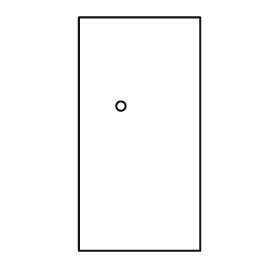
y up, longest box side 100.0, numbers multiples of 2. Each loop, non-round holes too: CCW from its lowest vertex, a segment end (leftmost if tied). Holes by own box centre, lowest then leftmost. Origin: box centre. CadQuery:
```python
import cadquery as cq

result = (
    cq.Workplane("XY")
    .moveTo(-26.0, -50.0)
    .lineTo(26.0, -50.0)
    .lineTo(26.0, 50.0)
    .lineTo(-26.0, 50.0)
    .close()
    .moveTo(-8.0, 12.0)
    .circle(2.0)
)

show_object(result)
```